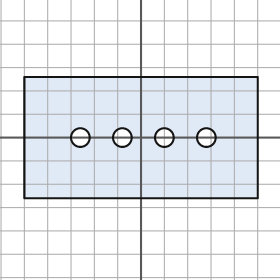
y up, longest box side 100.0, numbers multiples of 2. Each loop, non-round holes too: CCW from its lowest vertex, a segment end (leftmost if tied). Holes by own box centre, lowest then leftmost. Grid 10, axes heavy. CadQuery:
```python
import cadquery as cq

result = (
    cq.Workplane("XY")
    .moveTo(-50.0, -26.0)
    .lineTo(50.0, -26.0)
    .lineTo(50.0, 26.0)
    .lineTo(-50.0, 26.0)
    .close()
    .moveTo(-26.0, 0.0)
    .circle(4.0)
    .moveTo(-8.0, 0.0)
    .circle(4.0)
    .moveTo(10.0, 0.0)
    .circle(4.0)
    .moveTo(28.0, 0.0)
    .circle(4.0)
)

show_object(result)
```